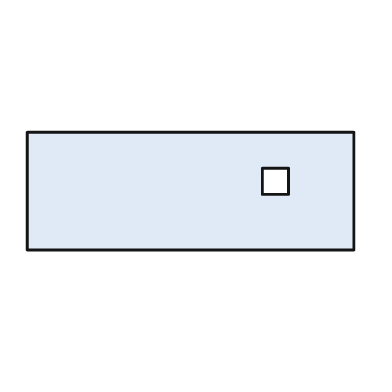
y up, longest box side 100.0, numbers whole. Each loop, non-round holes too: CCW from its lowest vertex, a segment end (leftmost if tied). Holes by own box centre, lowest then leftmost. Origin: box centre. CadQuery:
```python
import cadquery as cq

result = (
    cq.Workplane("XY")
    .moveTo(-50.0, -18.0)
    .lineTo(50.0, -18.0)
    .lineTo(50.0, 18.0)
    .lineTo(-50.0, 18.0)
    .close()
    .moveTo(22.0, -1.0)
    .lineTo(30.0, -1.0)
    .lineTo(30.0, 7.0)
    .lineTo(22.0, 7.0)
    .close()
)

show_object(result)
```